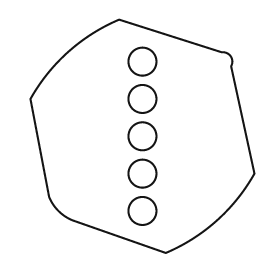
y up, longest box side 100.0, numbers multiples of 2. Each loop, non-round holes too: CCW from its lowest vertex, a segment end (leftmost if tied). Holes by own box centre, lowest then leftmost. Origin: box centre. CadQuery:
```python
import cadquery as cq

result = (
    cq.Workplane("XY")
    .moveTo(10.0, -50.0)
    .threePointArc((32.0, -36.0), (48.0, -16.0))
    .lineTo(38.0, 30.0)
    .threePointArc((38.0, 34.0), (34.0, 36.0))
    .lineTo(-10.0, 50.0)
    .threePointArc((-32.0, 36.0), (-48.0, 16.0))
    .lineTo(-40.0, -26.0)
    .threePointArc((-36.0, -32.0), (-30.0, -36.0))
    .close()
    .moveTo(0.0, -32.0)
    .circle(6.0)
    .moveTo(0.0, -16.0)
    .circle(6.0)
    .moveTo(0.0, 0.0)
    .circle(6.0)
    .moveTo(0.0, 16.0)
    .circle(6.0)
    .moveTo(0.0, 32.0)
    .circle(6.0)
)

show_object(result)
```